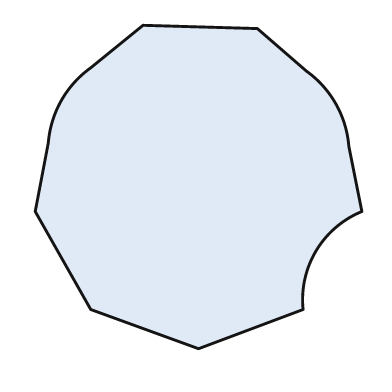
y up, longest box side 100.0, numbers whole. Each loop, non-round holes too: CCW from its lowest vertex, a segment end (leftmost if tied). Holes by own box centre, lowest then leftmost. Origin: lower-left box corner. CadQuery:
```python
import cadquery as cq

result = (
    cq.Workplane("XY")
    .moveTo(50.0, 0.0)
    .lineTo(82.0, 12.0)
    .threePointArc((86.0, 30.0), (100.0, 42.0))
    .lineTo(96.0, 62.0)
    .threePointArc((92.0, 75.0), (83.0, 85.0))
    .lineTo(68.0, 98.0)
    .lineTo(33.0, 99.0)
    .lineTo(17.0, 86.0)
    .threePointArc((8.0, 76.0), (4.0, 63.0))
    .lineTo(0.0, 42.0)
    .lineTo(17.0, 12.0)
    .close()
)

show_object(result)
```